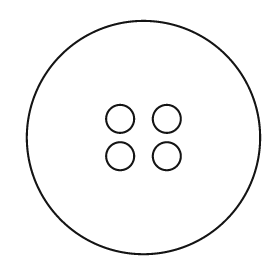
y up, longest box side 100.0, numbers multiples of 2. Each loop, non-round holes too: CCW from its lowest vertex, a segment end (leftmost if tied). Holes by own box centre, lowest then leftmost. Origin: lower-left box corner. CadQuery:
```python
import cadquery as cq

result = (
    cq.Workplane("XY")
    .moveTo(50.0, 50.0)
    .circle(50.0)
    .moveTo(40.0, 42.0)
    .circle(6.0)
    .moveTo(60.0, 42.0)
    .circle(6.0)
    .moveTo(40.0, 58.0)
    .circle(6.0)
    .moveTo(60.0, 58.0)
    .circle(6.0)
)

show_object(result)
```